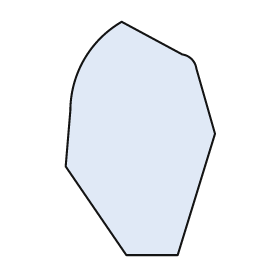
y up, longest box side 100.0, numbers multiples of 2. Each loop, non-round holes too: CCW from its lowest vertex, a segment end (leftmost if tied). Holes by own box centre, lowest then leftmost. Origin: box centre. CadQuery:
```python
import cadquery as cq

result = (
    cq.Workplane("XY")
    .moveTo(-6.0, -50.0)
    .lineTo(16.0, -50.0)
    .lineTo(32.0, 2.0)
    .lineTo(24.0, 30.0)
    .threePointArc((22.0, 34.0), (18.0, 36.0))
    .lineTo(-8.0, 50.0)
    .threePointArc((-24.0, 34.0), (-30.0, 12.0))
    .lineTo(-32.0, -12.0)
    .close()
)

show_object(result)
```